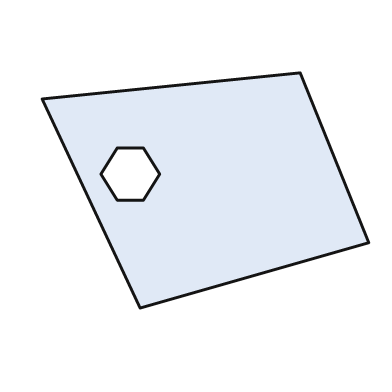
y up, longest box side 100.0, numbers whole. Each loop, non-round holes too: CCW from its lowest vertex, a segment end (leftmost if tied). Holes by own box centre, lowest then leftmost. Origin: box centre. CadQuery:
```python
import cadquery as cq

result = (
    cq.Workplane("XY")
    .moveTo(-20.0, -36.0)
    .lineTo(50.0, -16.0)
    .lineTo(29.0, 36.0)
    .lineTo(-50.0, 28.0)
    .close()
    .moveTo(-27.0, -3.0)
    .lineTo(-19.0, -3.0)
    .lineTo(-14.0, 5.0)
    .lineTo(-19.0, 13.0)
    .lineTo(-27.0, 13.0)
    .lineTo(-32.0, 5.0)
    .close()
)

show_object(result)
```